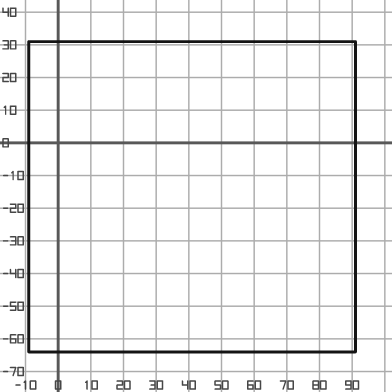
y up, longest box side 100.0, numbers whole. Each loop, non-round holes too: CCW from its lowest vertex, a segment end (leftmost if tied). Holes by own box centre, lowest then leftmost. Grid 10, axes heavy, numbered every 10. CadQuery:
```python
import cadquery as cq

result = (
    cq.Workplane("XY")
    .moveTo(-9.0, -64.0)
    .lineTo(91.0, -64.0)
    .lineTo(91.0, 31.0)
    .lineTo(-9.0, 31.0)
    .close()
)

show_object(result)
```